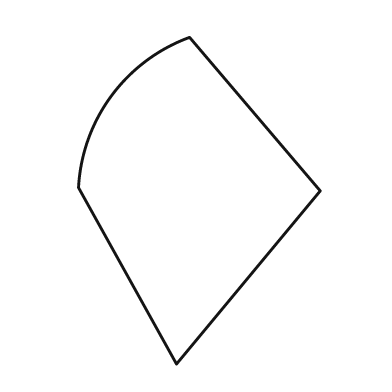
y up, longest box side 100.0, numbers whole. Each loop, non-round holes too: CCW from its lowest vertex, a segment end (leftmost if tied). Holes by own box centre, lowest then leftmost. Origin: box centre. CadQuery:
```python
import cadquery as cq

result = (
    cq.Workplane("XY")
    .moveTo(-7.0, -50.0)
    .lineTo(37.0, 3.0)
    .lineTo(-3.0, 50.0)
    .threePointArc((-27.0, 32.0), (-37.0, 4.0))
    .close()
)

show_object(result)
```